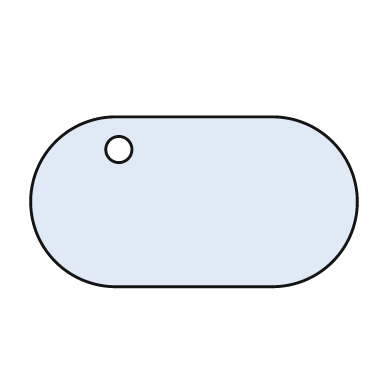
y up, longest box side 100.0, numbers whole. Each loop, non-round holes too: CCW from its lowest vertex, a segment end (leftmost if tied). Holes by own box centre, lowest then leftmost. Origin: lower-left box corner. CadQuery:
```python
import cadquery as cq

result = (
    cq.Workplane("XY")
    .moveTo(26.0, 0.0)
    .lineTo(74.0, 0.0)
    .threePointArc((100.0, 26.0), (74.0, 52.0))
    .lineTo(26.0, 52.0)
    .threePointArc((0.0, 26.0), (26.0, 0.0))
    .close()
    .moveTo(27.0, 42.0)
    .circle(4.0)
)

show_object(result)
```